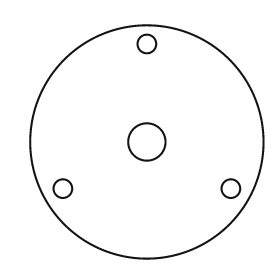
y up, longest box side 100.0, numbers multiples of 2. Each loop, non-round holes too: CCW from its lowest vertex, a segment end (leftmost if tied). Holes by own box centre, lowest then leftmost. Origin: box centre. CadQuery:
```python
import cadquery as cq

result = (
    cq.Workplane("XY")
    .moveTo(0.0, 0.0)
    .circle(50.0)
    .moveTo(-36.0, -20.0)
    .circle(4.0)
    .moveTo(36.0, -20.0)
    .circle(4.0)
    .moveTo(0.0, 0.0)
    .circle(8.0)
    .moveTo(0.0, 42.0)
    .circle(4.0)
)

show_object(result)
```